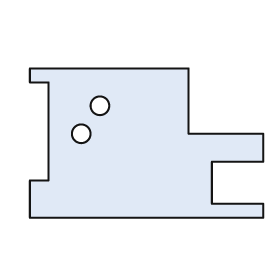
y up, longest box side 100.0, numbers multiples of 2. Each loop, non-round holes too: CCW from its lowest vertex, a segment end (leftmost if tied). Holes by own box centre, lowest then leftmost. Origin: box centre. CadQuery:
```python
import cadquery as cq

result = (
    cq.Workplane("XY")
    .moveTo(-50.0, -32.0)
    .lineTo(50.0, -32.0)
    .lineTo(50.0, -26.0)
    .lineTo(28.0, -26.0)
    .lineTo(28.0, -8.0)
    .lineTo(50.0, -8.0)
    .lineTo(50.0, 4.0)
    .lineTo(18.0, 4.0)
    .lineTo(18.0, 32.0)
    .lineTo(-50.0, 32.0)
    .lineTo(-50.0, 26.0)
    .lineTo(-42.0, 26.0)
    .lineTo(-42.0, -16.0)
    .lineTo(-50.0, -16.0)
    .close()
    .moveTo(-28.0, 4.0)
    .circle(4.0)
    .moveTo(-20.0, 16.0)
    .circle(4.0)
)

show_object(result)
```